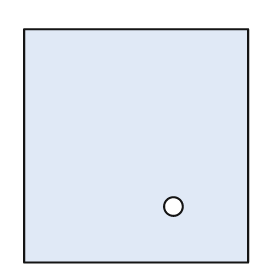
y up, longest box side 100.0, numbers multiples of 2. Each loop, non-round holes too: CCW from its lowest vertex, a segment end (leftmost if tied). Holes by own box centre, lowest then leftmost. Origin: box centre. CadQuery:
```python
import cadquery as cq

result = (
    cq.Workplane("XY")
    .moveTo(-48.0, -50.0)
    .lineTo(48.0, -50.0)
    .lineTo(48.0, 50.0)
    .lineTo(-48.0, 50.0)
    .close()
    .moveTo(16.0, -26.0)
    .circle(4.0)
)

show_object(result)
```